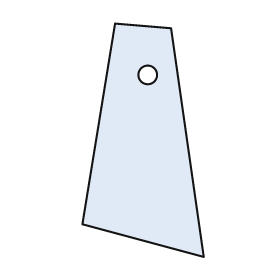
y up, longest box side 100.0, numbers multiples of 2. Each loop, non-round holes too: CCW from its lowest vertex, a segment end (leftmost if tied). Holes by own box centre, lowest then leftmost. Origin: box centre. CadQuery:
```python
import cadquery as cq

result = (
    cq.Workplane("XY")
    .moveTo(26.0, -50.0)
    .lineTo(12.0, 48.0)
    .lineTo(-12.0, 50.0)
    .lineTo(-26.0, -36.0)
    .close()
    .moveTo(2.0, 28.0)
    .circle(4.0)
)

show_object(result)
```